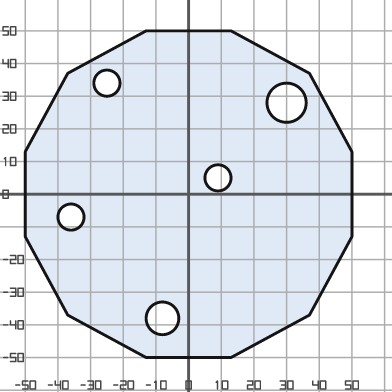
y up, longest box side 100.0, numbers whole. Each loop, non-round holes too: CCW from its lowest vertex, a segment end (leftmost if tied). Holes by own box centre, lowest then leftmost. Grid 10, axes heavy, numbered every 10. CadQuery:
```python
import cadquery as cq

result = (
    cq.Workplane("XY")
    .moveTo(-13.0, -50.0)
    .lineTo(13.0, -50.0)
    .lineTo(37.0, -37.0)
    .lineTo(50.0, -13.0)
    .lineTo(50.0, 13.0)
    .lineTo(37.0, 37.0)
    .lineTo(13.0, 50.0)
    .lineTo(-13.0, 50.0)
    .lineTo(-37.0, 37.0)
    .lineTo(-50.0, 13.0)
    .lineTo(-50.0, -13.0)
    .lineTo(-37.0, -37.0)
    .close()
    .moveTo(-8.0, -38.0)
    .circle(5.0)
    .moveTo(-36.0, -7.0)
    .circle(4.0)
    .moveTo(9.0, 5.0)
    .circle(4.0)
    .moveTo(30.0, 28.0)
    .circle(6.0)
    .moveTo(-25.0, 34.0)
    .circle(4.0)
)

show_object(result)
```